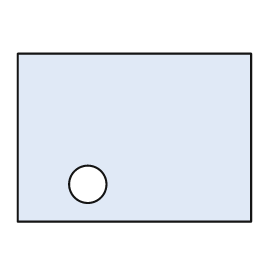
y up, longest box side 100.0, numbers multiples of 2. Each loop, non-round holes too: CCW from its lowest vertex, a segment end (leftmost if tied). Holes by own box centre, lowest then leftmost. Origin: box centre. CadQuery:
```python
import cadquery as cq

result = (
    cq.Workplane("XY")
    .moveTo(-50.0, -36.0)
    .lineTo(50.0, -36.0)
    .lineTo(50.0, 36.0)
    .lineTo(-50.0, 36.0)
    .close()
    .moveTo(-20.0, -20.0)
    .circle(8.0)
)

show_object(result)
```